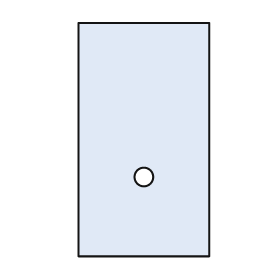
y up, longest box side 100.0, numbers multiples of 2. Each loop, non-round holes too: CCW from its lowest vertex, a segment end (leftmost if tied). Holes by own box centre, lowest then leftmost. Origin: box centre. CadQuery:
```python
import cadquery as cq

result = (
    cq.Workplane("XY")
    .moveTo(-28.0, -50.0)
    .lineTo(28.0, -50.0)
    .lineTo(28.0, 50.0)
    .lineTo(-28.0, 50.0)
    .close()
    .moveTo(0.0, -16.0)
    .circle(4.0)
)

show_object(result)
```